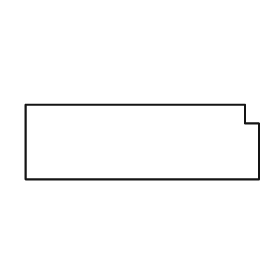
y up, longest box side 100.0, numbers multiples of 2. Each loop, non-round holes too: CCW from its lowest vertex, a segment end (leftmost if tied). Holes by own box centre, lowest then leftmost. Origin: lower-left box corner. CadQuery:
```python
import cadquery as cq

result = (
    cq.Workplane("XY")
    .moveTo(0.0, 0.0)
    .lineTo(100.0, 0.0)
    .lineTo(100.0, 24.0)
    .lineTo(94.0, 24.0)
    .lineTo(94.0, 32.0)
    .lineTo(0.0, 32.0)
    .close()
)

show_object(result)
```